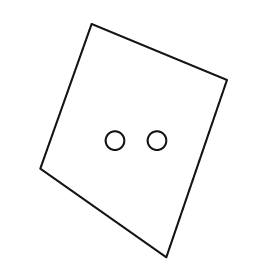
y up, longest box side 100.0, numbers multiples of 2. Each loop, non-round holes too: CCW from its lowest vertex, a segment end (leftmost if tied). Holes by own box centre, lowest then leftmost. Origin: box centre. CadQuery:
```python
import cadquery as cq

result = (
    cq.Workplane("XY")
    .moveTo(14.0, -50.0)
    .lineTo(40.0, 26.0)
    .lineTo(-18.0, 50.0)
    .lineTo(-40.0, -12.0)
    .close()
    .moveTo(-8.0, 0.0)
    .circle(4.0)
    .moveTo(10.0, 0.0)
    .circle(4.0)
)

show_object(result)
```